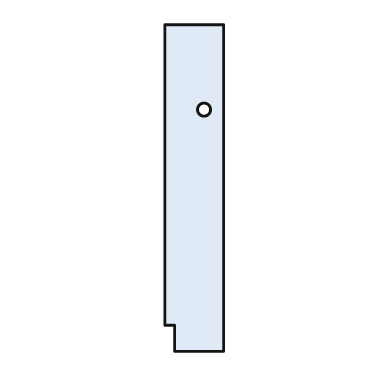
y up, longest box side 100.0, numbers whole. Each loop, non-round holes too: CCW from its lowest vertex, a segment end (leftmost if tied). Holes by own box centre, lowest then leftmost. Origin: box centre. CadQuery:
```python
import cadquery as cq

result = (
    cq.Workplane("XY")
    .moveTo(-6.0, -50.0)
    .lineTo(9.0, -50.0)
    .lineTo(9.0, 50.0)
    .lineTo(-9.0, 50.0)
    .lineTo(-9.0, -42.0)
    .lineTo(-6.0, -42.0)
    .close()
    .moveTo(3.0, 24.0)
    .circle(2.0)
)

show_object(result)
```